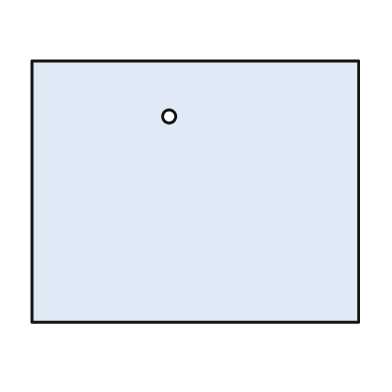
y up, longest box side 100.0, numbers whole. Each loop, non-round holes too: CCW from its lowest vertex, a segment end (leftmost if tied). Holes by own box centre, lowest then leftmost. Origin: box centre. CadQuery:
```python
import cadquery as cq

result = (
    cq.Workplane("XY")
    .moveTo(-50.0, -40.0)
    .lineTo(50.0, -40.0)
    .lineTo(50.0, 40.0)
    .lineTo(-50.0, 40.0)
    .close()
    .moveTo(-8.0, 23.0)
    .circle(2.0)
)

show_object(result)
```